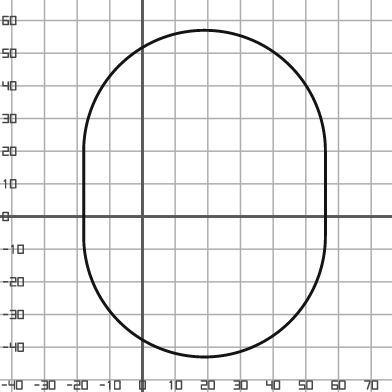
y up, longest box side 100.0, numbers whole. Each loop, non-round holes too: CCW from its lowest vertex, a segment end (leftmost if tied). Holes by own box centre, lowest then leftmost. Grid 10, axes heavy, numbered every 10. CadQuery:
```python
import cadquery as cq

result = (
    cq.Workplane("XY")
    .moveTo(-18.0, -6.0)
    .threePointArc((19.0, -43.0), (56.0, -6.0))
    .lineTo(56.0, 20.0)
    .threePointArc((19.0, 57.0), (-18.0, 20.0))
    .close()
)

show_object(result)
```